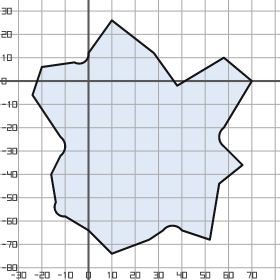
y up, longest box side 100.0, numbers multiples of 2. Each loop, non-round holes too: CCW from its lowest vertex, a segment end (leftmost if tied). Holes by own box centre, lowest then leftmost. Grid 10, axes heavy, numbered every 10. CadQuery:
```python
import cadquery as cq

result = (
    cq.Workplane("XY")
    .moveTo(10.0, -74.0)
    .lineTo(26.0, -68.0)
    .lineTo(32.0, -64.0)
    .threePointArc((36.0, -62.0), (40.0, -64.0))
    .lineTo(52.0, -68.0)
    .lineTo(56.0, -44.0)
    .lineTo(66.0, -36.0)
    .lineTo(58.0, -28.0)
    .threePointArc((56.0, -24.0), (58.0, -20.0))
    .lineTo(70.0, 0.0)
    .lineTo(58.0, 10.0)
    .lineTo(38.0, -2.0)
    .lineTo(28.0, 12.0)
    .lineTo(10.0, 26.0)
    .lineTo(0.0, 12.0)
    .threePointArc((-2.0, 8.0), (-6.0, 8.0))
    .lineTo(-20.0, 6.0)
    .lineTo(-24.0, -6.0)
    .lineTo(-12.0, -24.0)
    .threePointArc((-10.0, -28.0), (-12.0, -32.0))
    .lineTo(-16.0, -40.0)
    .lineTo(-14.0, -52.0)
    .threePointArc((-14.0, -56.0), (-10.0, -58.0))
    .lineTo(0.0, -64.0)
    .close()
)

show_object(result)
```